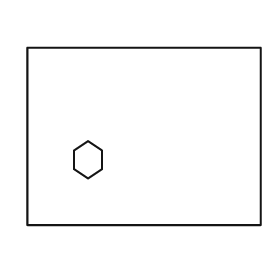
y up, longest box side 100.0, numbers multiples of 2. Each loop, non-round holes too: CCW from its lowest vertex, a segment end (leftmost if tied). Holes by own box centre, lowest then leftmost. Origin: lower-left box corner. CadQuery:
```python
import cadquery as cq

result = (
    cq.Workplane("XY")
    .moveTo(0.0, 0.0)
    .lineTo(100.0, 0.0)
    .lineTo(100.0, 76.0)
    .lineTo(0.0, 76.0)
    .close()
    .moveTo(26.0, 20.0)
    .lineTo(32.0, 24.0)
    .lineTo(32.0, 32.0)
    .lineTo(26.0, 36.0)
    .lineTo(20.0, 32.0)
    .lineTo(20.0, 24.0)
    .close()
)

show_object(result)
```